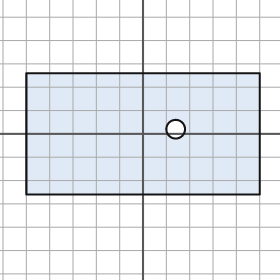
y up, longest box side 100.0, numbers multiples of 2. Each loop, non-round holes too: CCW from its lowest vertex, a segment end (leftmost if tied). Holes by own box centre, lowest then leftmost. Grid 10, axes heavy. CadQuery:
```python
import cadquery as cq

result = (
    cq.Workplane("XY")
    .moveTo(-50.0, -26.0)
    .lineTo(50.0, -26.0)
    .lineTo(50.0, 26.0)
    .lineTo(-50.0, 26.0)
    .close()
    .moveTo(14.0, 2.0)
    .circle(4.0)
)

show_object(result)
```